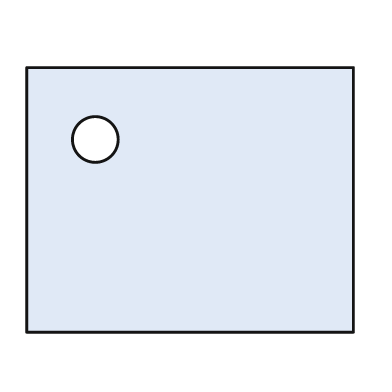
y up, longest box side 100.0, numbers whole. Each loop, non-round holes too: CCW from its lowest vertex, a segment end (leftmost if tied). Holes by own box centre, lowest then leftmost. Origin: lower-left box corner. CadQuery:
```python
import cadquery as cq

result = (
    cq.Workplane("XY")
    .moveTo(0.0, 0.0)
    .lineTo(100.0, 0.0)
    .lineTo(100.0, 81.0)
    .lineTo(0.0, 81.0)
    .close()
    .moveTo(21.0, 59.0)
    .circle(7.0)
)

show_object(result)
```